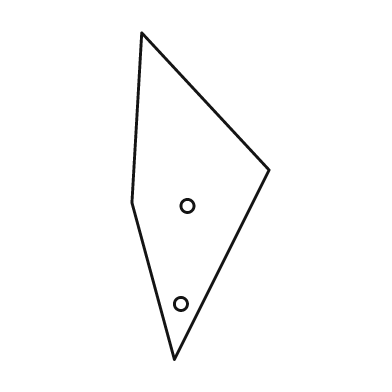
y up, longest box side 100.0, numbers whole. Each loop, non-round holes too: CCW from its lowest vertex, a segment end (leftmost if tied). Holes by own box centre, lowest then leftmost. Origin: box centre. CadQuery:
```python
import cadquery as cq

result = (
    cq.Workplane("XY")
    .moveTo(-8.0, -50.0)
    .lineTo(21.0, 8.0)
    .lineTo(-18.0, 50.0)
    .lineTo(-21.0, -2.0)
    .close()
    .moveTo(-6.0, -33.0)
    .circle(2.0)
    .moveTo(-4.0, -3.0)
    .circle(2.0)
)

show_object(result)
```